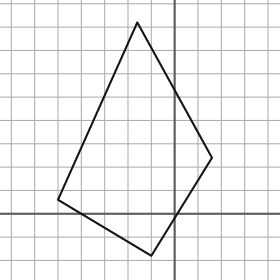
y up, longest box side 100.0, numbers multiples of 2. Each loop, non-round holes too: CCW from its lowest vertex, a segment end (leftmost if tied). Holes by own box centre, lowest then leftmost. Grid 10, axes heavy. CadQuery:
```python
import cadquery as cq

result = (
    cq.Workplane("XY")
    .moveTo(-10.0, -18.0)
    .lineTo(16.0, 24.0)
    .lineTo(-16.0, 82.0)
    .lineTo(-50.0, 6.0)
    .close()
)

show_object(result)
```